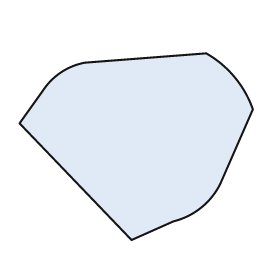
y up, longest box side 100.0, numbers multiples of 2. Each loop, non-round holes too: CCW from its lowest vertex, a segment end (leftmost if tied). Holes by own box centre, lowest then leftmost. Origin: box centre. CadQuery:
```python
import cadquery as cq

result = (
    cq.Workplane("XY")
    .moveTo(-2.0, -40.0)
    .lineTo(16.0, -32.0)
    .threePointArc((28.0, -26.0), (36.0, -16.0))
    .lineTo(50.0, 16.0)
    .threePointArc((42.0, 30.0), (30.0, 40.0))
    .lineTo(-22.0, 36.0)
    .threePointArc((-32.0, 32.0), (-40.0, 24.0))
    .lineTo(-50.0, 10.0)
    .close()
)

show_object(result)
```